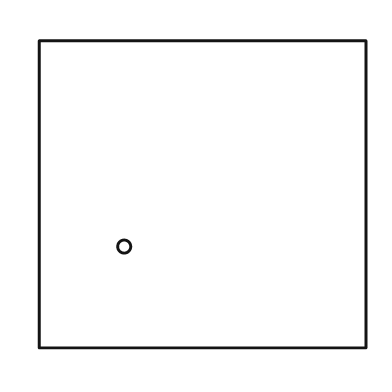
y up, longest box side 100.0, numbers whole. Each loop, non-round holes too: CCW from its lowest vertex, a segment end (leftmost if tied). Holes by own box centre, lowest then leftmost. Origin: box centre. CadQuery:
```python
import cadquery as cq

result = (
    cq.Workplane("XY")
    .moveTo(-50.0, -47.0)
    .lineTo(50.0, -47.0)
    .lineTo(50.0, 47.0)
    .lineTo(-50.0, 47.0)
    .close()
    .moveTo(-24.0, -16.0)
    .circle(2.0)
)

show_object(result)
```